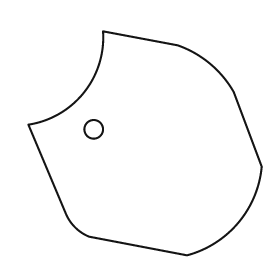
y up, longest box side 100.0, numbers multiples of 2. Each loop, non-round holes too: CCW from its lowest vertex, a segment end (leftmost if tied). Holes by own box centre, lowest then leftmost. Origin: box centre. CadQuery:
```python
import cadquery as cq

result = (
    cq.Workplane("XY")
    .moveTo(18.0, -48.0)
    .threePointArc((40.0, -34.0), (50.0, -10.0))
    .lineTo(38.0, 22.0)
    .threePointArc((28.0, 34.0), (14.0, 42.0))
    .lineTo(-18.0, 48.0)
    .threePointArc((-26.0, 22.0), (-50.0, 8.0))
    .lineTo(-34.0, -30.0)
    .threePointArc((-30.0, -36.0), (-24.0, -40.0))
    .close()
    .moveTo(-22.0, 6.0)
    .circle(4.0)
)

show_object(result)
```